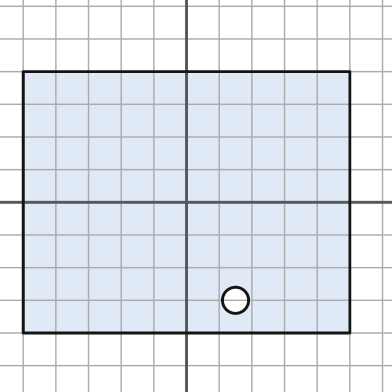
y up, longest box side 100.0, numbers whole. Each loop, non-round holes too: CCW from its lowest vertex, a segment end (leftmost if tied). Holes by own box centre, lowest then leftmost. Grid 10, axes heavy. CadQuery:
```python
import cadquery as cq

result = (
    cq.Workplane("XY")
    .moveTo(-50.0, -40.0)
    .lineTo(50.0, -40.0)
    .lineTo(50.0, 40.0)
    .lineTo(-50.0, 40.0)
    .close()
    .moveTo(15.0, -30.0)
    .circle(4.0)
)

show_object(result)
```